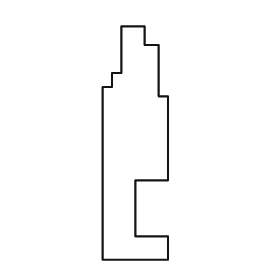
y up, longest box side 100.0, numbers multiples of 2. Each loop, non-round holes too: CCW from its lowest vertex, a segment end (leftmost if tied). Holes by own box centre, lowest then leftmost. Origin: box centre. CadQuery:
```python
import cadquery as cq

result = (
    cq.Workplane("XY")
    .moveTo(-14.0, -50.0)
    .lineTo(14.0, -50.0)
    .lineTo(14.0, -40.0)
    .lineTo(0.0, -40.0)
    .lineTo(0.0, -16.0)
    .lineTo(14.0, -16.0)
    .lineTo(14.0, 20.0)
    .lineTo(10.0, 20.0)
    .lineTo(10.0, 42.0)
    .lineTo(4.0, 42.0)
    .lineTo(4.0, 50.0)
    .lineTo(-6.0, 50.0)
    .lineTo(-6.0, 30.0)
    .lineTo(-10.0, 30.0)
    .lineTo(-10.0, 24.0)
    .lineTo(-14.0, 24.0)
    .close()
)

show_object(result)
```